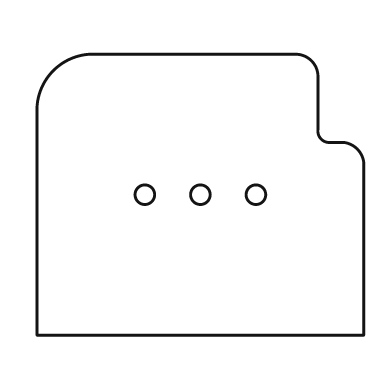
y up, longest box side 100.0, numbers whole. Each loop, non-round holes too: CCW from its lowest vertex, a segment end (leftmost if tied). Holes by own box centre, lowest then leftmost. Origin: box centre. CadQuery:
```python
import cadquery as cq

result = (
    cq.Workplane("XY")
    .moveTo(-50.0, -43.0)
    .lineTo(50.0, -43.0)
    .lineTo(50.0, 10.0)
    .threePointArc((48.0, 14.0), (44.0, 16.0))
    .lineTo(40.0, 16.0)
    .threePointArc((37.0, 17.0), (36.0, 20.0))
    .lineTo(36.0, 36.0)
    .threePointArc((34.0, 41.0), (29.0, 43.0))
    .lineTo(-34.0, 43.0)
    .threePointArc((-45.0, 38.0), (-50.0, 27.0))
    .close()
    .moveTo(-17.0, 0.0)
    .circle(3.0)
    .moveTo(0.0, 0.0)
    .circle(3.0)
    .moveTo(17.0, 0.0)
    .circle(3.0)
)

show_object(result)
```